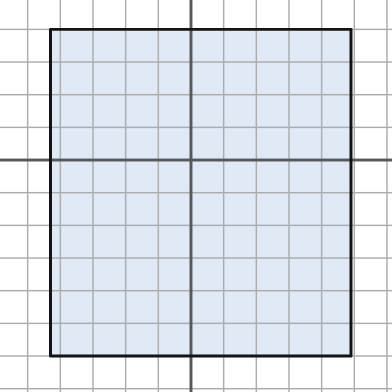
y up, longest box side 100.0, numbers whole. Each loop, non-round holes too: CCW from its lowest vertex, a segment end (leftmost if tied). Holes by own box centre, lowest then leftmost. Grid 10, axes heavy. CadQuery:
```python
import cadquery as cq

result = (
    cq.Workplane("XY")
    .moveTo(-43.0, -60.0)
    .lineTo(49.0, -60.0)
    .lineTo(49.0, 40.0)
    .lineTo(-43.0, 40.0)
    .close()
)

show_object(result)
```